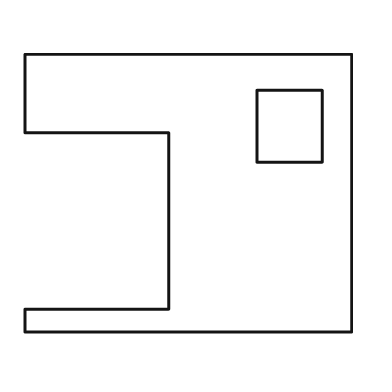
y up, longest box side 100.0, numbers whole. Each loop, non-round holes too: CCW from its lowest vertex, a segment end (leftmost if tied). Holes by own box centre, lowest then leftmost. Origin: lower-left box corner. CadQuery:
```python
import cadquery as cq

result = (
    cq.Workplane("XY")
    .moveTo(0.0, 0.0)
    .lineTo(100.0, 0.0)
    .lineTo(100.0, 85.0)
    .lineTo(0.0, 85.0)
    .lineTo(0.0, 61.0)
    .lineTo(44.0, 61.0)
    .lineTo(44.0, 7.0)
    .lineTo(0.0, 7.0)
    .close()
    .moveTo(71.0, 52.0)
    .lineTo(91.0, 52.0)
    .lineTo(91.0, 74.0)
    .lineTo(71.0, 74.0)
    .close()
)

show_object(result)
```